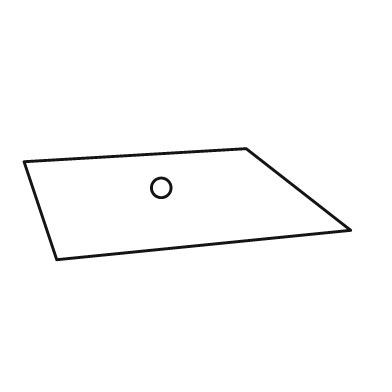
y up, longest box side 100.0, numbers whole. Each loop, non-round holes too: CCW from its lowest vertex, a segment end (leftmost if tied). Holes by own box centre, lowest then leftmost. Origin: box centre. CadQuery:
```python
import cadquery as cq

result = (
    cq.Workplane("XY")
    .moveTo(-40.0, -17.0)
    .lineTo(50.0, -8.0)
    .lineTo(18.0, 17.0)
    .lineTo(-50.0, 13.0)
    .close()
    .moveTo(-8.0, 5.0)
    .circle(3.0)
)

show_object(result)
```